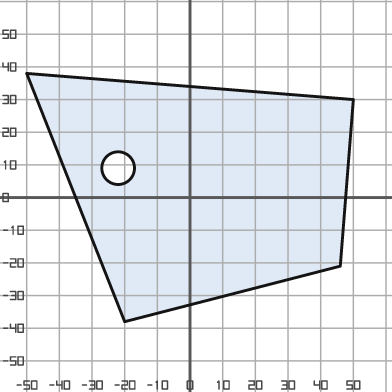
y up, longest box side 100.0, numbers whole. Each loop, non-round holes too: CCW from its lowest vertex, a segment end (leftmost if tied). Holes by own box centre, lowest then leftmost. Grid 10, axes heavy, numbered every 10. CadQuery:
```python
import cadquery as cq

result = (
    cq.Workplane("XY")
    .moveTo(-20.0, -38.0)
    .lineTo(46.0, -21.0)
    .lineTo(50.0, 30.0)
    .lineTo(-50.0, 38.0)
    .close()
    .moveTo(-22.0, 9.0)
    .circle(5.0)
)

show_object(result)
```